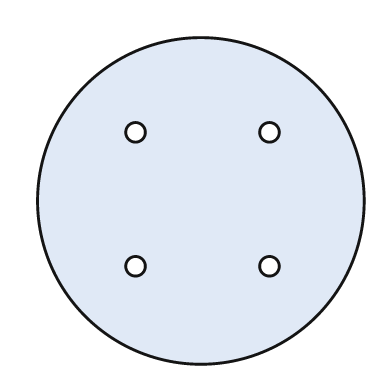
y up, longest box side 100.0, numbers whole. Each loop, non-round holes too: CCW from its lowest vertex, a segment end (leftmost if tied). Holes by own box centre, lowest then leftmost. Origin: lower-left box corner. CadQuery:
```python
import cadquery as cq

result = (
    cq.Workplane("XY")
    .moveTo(50.0, 50.0)
    .circle(50.0)
    .moveTo(30.0, 30.0)
    .circle(3.0)
    .moveTo(71.0, 30.0)
    .circle(3.0)
    .moveTo(30.0, 71.0)
    .circle(3.0)
    .moveTo(71.0, 71.0)
    .circle(3.0)
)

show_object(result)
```